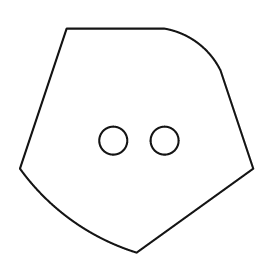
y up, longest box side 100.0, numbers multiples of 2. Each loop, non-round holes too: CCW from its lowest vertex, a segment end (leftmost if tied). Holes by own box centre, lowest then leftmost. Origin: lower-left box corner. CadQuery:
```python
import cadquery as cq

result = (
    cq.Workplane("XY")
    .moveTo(50.0, 0.0)
    .lineTo(100.0, 36.0)
    .lineTo(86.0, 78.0)
    .threePointArc((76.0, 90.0), (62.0, 96.0))
    .lineTo(20.0, 96.0)
    .lineTo(0.0, 36.0)
    .threePointArc((22.0, 14.0), (50.0, 0.0))
    .close()
    .moveTo(40.0, 48.0)
    .circle(6.0)
    .moveTo(62.0, 48.0)
    .circle(6.0)
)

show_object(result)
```